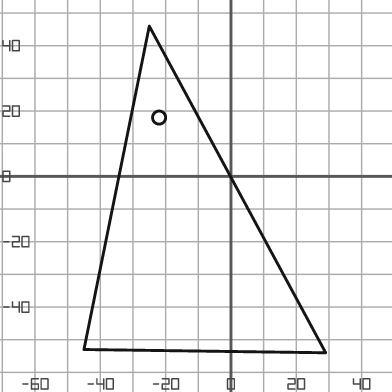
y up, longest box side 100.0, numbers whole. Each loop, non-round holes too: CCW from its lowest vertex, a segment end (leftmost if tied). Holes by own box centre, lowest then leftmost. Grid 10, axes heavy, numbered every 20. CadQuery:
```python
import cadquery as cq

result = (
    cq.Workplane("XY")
    .moveTo(29.0, -54.0)
    .lineTo(-25.0, 46.0)
    .lineTo(-45.0, -53.0)
    .close()
    .moveTo(-22.0, 18.0)
    .circle(2.0)
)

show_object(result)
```